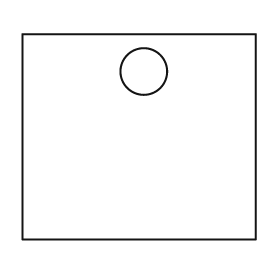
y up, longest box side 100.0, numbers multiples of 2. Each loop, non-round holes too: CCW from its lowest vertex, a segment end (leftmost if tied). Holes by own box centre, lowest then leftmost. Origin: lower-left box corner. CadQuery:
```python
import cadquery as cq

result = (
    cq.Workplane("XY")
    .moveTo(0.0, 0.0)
    .lineTo(100.0, 0.0)
    .lineTo(100.0, 88.0)
    .lineTo(0.0, 88.0)
    .close()
    .moveTo(52.0, 72.0)
    .circle(10.0)
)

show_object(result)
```